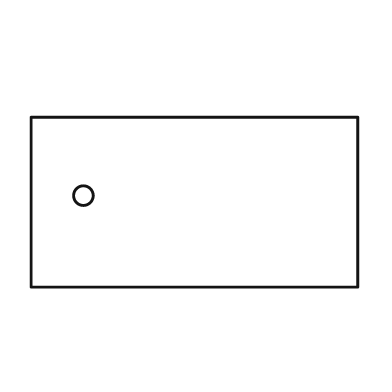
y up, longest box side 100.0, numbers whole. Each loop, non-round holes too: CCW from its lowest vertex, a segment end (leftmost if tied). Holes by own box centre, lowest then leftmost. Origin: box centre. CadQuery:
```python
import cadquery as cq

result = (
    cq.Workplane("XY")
    .moveTo(-50.0, -26.0)
    .lineTo(50.0, -26.0)
    .lineTo(50.0, 26.0)
    .lineTo(-50.0, 26.0)
    .close()
    .moveTo(-34.0, 2.0)
    .circle(3.0)
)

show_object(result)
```